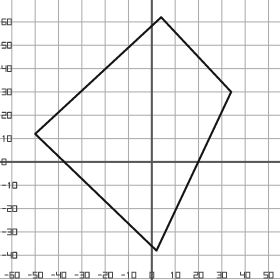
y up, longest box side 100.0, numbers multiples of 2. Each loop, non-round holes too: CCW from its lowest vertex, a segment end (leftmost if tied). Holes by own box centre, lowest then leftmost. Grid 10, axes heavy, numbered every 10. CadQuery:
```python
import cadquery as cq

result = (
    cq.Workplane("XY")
    .moveTo(2.0, -38.0)
    .lineTo(34.0, 30.0)
    .lineTo(4.0, 62.0)
    .lineTo(-50.0, 12.0)
    .close()
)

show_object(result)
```